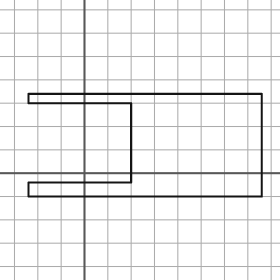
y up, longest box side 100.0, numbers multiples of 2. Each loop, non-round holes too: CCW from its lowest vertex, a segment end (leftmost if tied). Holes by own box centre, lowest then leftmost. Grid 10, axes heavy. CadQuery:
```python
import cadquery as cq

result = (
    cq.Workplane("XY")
    .moveTo(-24.0, -10.0)
    .lineTo(76.0, -10.0)
    .lineTo(76.0, 34.0)
    .lineTo(-24.0, 34.0)
    .lineTo(-24.0, 30.0)
    .lineTo(20.0, 30.0)
    .lineTo(20.0, -4.0)
    .lineTo(-24.0, -4.0)
    .close()
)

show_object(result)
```